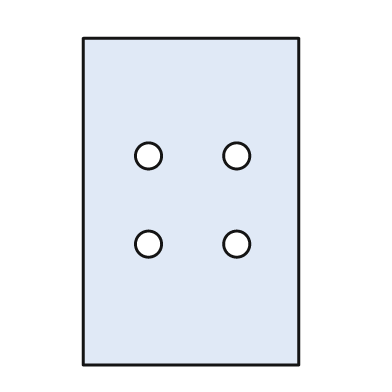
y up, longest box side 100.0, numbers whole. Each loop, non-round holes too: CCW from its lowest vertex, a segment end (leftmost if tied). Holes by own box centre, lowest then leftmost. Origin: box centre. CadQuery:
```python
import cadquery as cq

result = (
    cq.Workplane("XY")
    .moveTo(-33.0, -50.0)
    .lineTo(33.0, -50.0)
    .lineTo(33.0, 50.0)
    .lineTo(-33.0, 50.0)
    .close()
    .moveTo(-13.0, -13.0)
    .circle(4.0)
    .moveTo(14.0, -13.0)
    .circle(4.0)
    .moveTo(-13.0, 14.0)
    .circle(4.0)
    .moveTo(14.0, 14.0)
    .circle(4.0)
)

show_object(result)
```